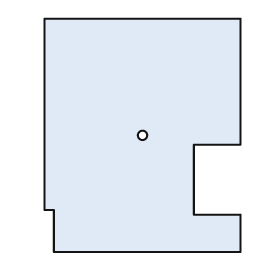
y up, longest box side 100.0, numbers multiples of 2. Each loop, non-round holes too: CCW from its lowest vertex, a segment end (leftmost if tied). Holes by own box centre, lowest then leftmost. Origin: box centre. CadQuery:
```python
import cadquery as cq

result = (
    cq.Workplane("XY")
    .moveTo(-38.0, -50.0)
    .lineTo(42.0, -50.0)
    .lineTo(42.0, -34.0)
    .lineTo(22.0, -34.0)
    .lineTo(22.0, -4.0)
    .lineTo(42.0, -4.0)
    .lineTo(42.0, 50.0)
    .lineTo(-42.0, 50.0)
    .lineTo(-42.0, -32.0)
    .lineTo(-38.0, -32.0)
    .close()
    .moveTo(0.0, 0.0)
    .circle(2.0)
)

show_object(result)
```